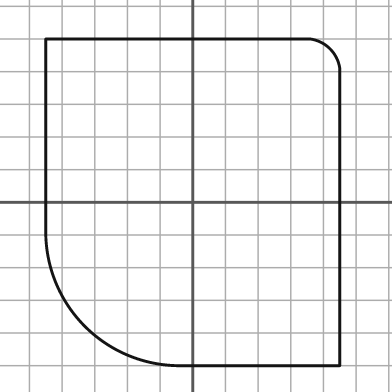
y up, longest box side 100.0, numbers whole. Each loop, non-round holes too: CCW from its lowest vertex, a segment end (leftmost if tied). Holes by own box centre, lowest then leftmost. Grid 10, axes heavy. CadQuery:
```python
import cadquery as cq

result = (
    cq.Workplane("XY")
    .moveTo(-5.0, -50.0)
    .lineTo(45.0, -50.0)
    .lineTo(45.0, 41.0)
    .threePointArc((42.0, 47.0), (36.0, 50.0))
    .lineTo(-45.0, 50.0)
    .lineTo(-45.0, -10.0)
    .threePointArc((-33.0, -38.0), (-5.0, -50.0))
    .close()
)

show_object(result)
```